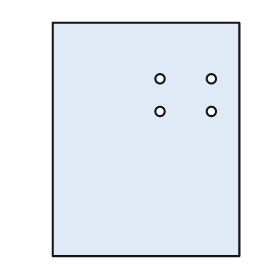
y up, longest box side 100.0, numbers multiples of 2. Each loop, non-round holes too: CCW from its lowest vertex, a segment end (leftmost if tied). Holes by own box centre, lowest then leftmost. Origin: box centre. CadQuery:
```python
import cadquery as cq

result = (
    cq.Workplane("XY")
    .moveTo(-40.0, -50.0)
    .lineTo(40.0, -50.0)
    .lineTo(40.0, 50.0)
    .lineTo(-40.0, 50.0)
    .close()
    .moveTo(6.0, 12.0)
    .circle(2.0)
    .moveTo(28.0, 12.0)
    .circle(2.0)
    .moveTo(6.0, 26.0)
    .circle(2.0)
    .moveTo(28.0, 26.0)
    .circle(2.0)
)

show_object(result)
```